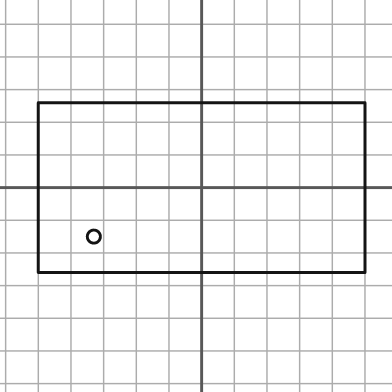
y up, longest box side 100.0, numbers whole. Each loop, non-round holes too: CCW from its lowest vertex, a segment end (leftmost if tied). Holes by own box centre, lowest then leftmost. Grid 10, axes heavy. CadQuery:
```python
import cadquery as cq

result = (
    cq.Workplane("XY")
    .moveTo(-50.0, -26.0)
    .lineTo(50.0, -26.0)
    .lineTo(50.0, 26.0)
    .lineTo(-50.0, 26.0)
    .close()
    .moveTo(-33.0, -15.0)
    .circle(2.0)
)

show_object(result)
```